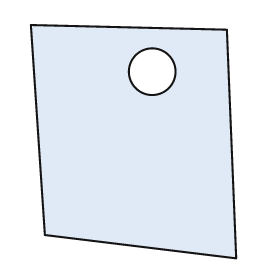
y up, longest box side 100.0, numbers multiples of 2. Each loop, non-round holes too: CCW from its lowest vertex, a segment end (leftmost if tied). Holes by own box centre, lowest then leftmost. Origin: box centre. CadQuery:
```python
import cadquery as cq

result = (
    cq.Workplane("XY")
    .moveTo(44.0, -50.0)
    .lineTo(40.0, 48.0)
    .lineTo(-44.0, 50.0)
    .lineTo(-38.0, -40.0)
    .close()
    .moveTo(8.0, 30.0)
    .circle(10.0)
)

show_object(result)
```